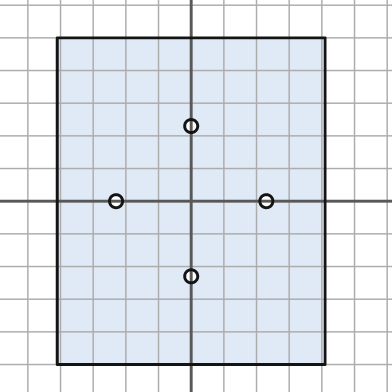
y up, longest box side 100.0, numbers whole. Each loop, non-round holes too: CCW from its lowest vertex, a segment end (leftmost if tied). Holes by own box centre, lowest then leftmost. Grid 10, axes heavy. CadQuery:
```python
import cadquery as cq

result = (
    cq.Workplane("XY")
    .moveTo(-41.0, -50.0)
    .lineTo(41.0, -50.0)
    .lineTo(41.0, 50.0)
    .lineTo(-41.0, 50.0)
    .close()
    .moveTo(0.0, -23.0)
    .circle(2.0)
    .moveTo(-23.0, 0.0)
    .circle(2.0)
    .moveTo(23.0, 0.0)
    .circle(2.0)
    .moveTo(0.0, 23.0)
    .circle(2.0)
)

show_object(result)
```